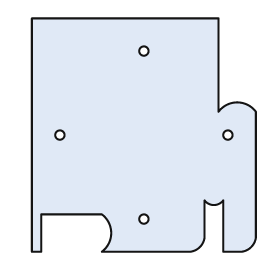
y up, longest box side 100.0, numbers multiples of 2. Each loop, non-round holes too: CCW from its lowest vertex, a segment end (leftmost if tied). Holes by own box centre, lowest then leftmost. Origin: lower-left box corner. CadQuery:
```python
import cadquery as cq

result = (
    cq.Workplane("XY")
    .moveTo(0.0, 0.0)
    .lineTo(4.0, 0.0)
    .lineTo(4.0, 16.0)
    .lineTo(30.0, 16.0)
    .threePointArc((34.0, 8.0), (30.0, 0.0))
    .lineTo(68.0, 0.0)
    .threePointArc((72.0, 2.0), (74.0, 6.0))
    .lineTo(74.0, 22.0)
    .threePointArc((78.0, 20.0), (82.0, 22.0))
    .lineTo(82.0, 0.0)
    .lineTo(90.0, 0.0)
    .threePointArc((94.0, 2.0), (96.0, 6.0))
    .lineTo(96.0, 60.0)
    .threePointArc((88.0, 64.0), (80.0, 60.0))
    .lineTo(80.0, 100.0)
    .lineTo(0.0, 100.0)
    .close()
    .moveTo(48.0, 14.0)
    .circle(2.0)
    .moveTo(12.0, 50.0)
    .circle(2.0)
    .moveTo(84.0, 50.0)
    .circle(2.0)
    .moveTo(48.0, 86.0)
    .circle(2.0)
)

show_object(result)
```